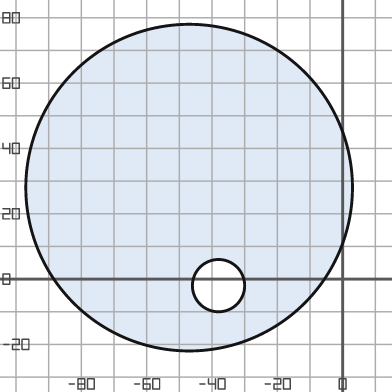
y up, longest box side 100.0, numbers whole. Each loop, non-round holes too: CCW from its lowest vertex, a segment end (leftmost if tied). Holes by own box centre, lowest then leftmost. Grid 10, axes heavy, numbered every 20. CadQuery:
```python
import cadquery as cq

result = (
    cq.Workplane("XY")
    .moveTo(-47.0, 28.0)
    .circle(50.0)
    .moveTo(-38.0, -2.0)
    .circle(8.0)
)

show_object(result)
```